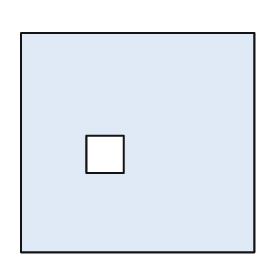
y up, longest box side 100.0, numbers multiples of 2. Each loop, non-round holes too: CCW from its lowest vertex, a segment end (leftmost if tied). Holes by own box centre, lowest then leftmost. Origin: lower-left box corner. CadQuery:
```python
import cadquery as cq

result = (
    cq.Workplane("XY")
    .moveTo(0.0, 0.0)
    .lineTo(100.0, 0.0)
    .lineTo(100.0, 94.0)
    .lineTo(0.0, 94.0)
    .close()
    .moveTo(28.0, 34.0)
    .lineTo(44.0, 34.0)
    .lineTo(44.0, 50.0)
    .lineTo(28.0, 50.0)
    .close()
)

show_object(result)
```